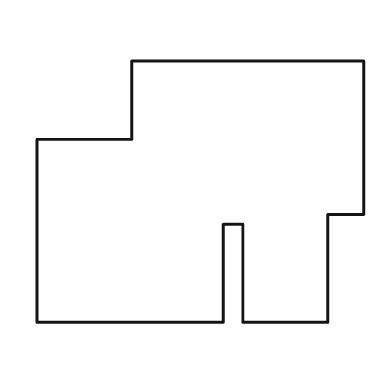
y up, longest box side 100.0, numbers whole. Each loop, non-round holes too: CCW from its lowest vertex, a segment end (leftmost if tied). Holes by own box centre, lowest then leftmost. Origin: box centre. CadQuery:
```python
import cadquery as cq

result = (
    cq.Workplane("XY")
    .moveTo(-50.0, -40.0)
    .lineTo(7.0, -40.0)
    .lineTo(7.0, -10.0)
    .lineTo(13.0, -10.0)
    .lineTo(13.0, -40.0)
    .lineTo(39.0, -40.0)
    .lineTo(39.0, -7.0)
    .lineTo(50.0, -7.0)
    .lineTo(50.0, 40.0)
    .lineTo(-21.0, 40.0)
    .lineTo(-21.0, 16.0)
    .lineTo(-50.0, 16.0)
    .close()
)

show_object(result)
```